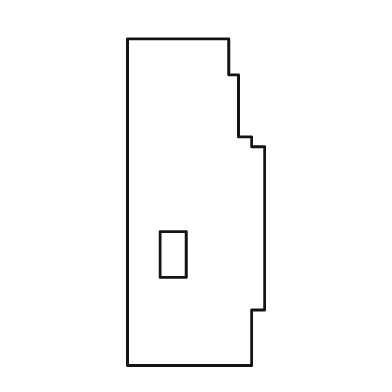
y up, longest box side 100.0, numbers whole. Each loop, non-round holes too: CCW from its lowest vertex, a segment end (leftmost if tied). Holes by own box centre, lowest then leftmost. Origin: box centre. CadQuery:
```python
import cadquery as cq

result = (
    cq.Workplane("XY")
    .moveTo(-21.0, -50.0)
    .lineTo(17.0, -50.0)
    .lineTo(17.0, -33.0)
    .lineTo(21.0, -33.0)
    .lineTo(21.0, 17.0)
    .lineTo(17.0, 17.0)
    .lineTo(17.0, 20.0)
    .lineTo(13.0, 20.0)
    .lineTo(13.0, 39.0)
    .lineTo(10.0, 39.0)
    .lineTo(10.0, 50.0)
    .lineTo(-21.0, 50.0)
    .close()
    .moveTo(-11.0, -23.0)
    .lineTo(-3.0, -23.0)
    .lineTo(-3.0, -9.0)
    .lineTo(-11.0, -9.0)
    .close()
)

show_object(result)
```